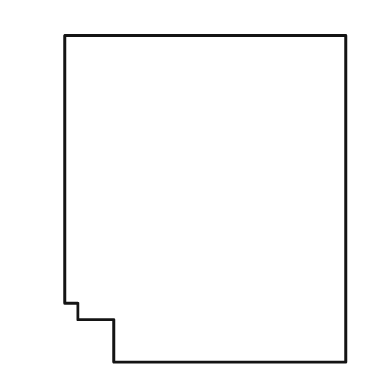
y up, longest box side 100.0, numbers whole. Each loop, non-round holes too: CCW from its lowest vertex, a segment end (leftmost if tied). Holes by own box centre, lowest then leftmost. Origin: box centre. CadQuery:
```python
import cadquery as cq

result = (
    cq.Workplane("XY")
    .moveTo(-28.0, -50.0)
    .lineTo(43.0, -50.0)
    .lineTo(43.0, 50.0)
    .lineTo(-43.0, 50.0)
    .lineTo(-43.0, -32.0)
    .lineTo(-39.0, -32.0)
    .lineTo(-39.0, -37.0)
    .lineTo(-28.0, -37.0)
    .close()
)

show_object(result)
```